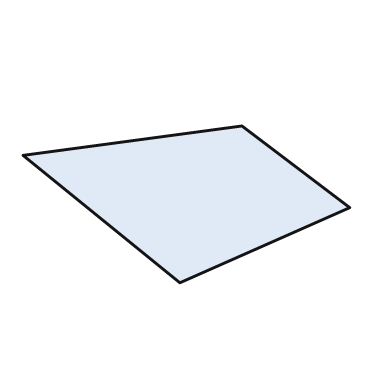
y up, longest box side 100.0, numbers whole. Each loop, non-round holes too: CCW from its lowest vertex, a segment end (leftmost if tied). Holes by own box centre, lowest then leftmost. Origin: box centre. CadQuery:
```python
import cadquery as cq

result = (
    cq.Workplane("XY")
    .moveTo(-2.0, -24.0)
    .lineTo(50.0, -1.0)
    .lineTo(17.0, 24.0)
    .lineTo(-50.0, 15.0)
    .close()
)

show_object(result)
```